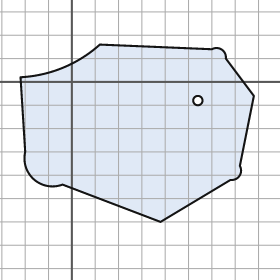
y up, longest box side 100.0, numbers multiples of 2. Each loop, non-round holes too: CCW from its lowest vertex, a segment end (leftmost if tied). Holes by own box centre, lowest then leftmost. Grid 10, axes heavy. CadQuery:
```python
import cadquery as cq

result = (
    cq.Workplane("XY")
    .moveTo(38.0, -60.0)
    .lineTo(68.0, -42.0)
    .threePointArc((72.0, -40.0), (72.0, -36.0))
    .lineTo(78.0, -6.0)
    .lineTo(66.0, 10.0)
    .threePointArc((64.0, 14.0), (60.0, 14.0))
    .lineTo(12.0, 16.0)
    .threePointArc((-4.0, 6.0), (-22.0, 2.0))
    .lineTo(-20.0, -30.0)
    .threePointArc((-16.0, -42.0), (-4.0, -44.0))
    .close()
    .moveTo(54.0, -8.0)
    .circle(2.0)
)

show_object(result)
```